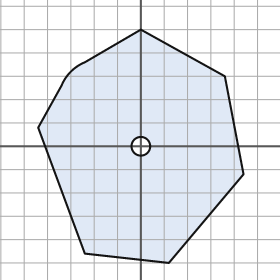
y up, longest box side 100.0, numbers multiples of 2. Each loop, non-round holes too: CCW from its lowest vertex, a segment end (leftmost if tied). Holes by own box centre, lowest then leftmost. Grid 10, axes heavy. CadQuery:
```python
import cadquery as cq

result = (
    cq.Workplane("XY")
    .moveTo(12.0, -50.0)
    .lineTo(44.0, -12.0)
    .lineTo(36.0, 30.0)
    .lineTo(0.0, 50.0)
    .lineTo(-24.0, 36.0)
    .threePointArc((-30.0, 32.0), (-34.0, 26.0))
    .lineTo(-44.0, 8.0)
    .lineTo(-24.0, -46.0)
    .close()
    .moveTo(0.0, 0.0)
    .circle(4.0)
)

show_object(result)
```